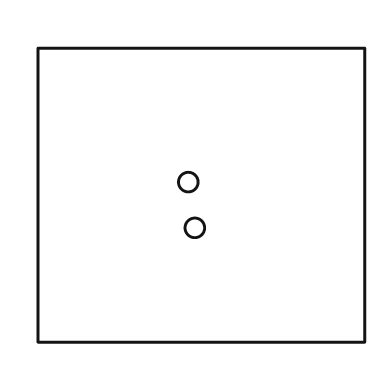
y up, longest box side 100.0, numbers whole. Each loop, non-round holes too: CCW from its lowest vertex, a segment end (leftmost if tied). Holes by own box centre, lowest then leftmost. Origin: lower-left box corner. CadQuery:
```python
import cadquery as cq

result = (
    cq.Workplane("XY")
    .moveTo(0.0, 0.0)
    .lineTo(100.0, 0.0)
    .lineTo(100.0, 90.0)
    .lineTo(0.0, 90.0)
    .close()
    .moveTo(48.0, 35.0)
    .circle(3.0)
    .moveTo(46.0, 49.0)
    .circle(3.0)
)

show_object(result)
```